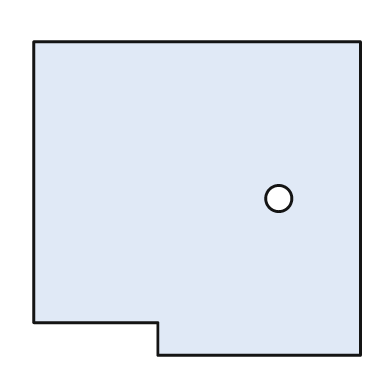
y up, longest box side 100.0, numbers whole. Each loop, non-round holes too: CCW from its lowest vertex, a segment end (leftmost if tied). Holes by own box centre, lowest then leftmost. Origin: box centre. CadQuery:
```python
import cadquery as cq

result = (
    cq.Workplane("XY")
    .moveTo(-12.0, -48.0)
    .lineTo(50.0, -48.0)
    .lineTo(50.0, 48.0)
    .lineTo(-50.0, 48.0)
    .lineTo(-50.0, -38.0)
    .lineTo(-12.0, -38.0)
    .close()
    .moveTo(25.0, 0.0)
    .circle(4.0)
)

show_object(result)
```